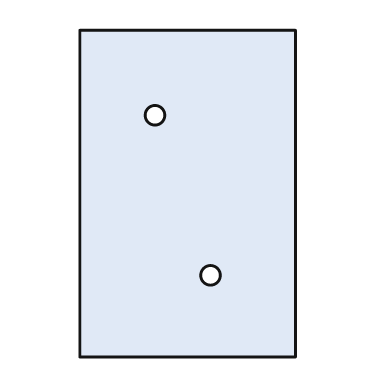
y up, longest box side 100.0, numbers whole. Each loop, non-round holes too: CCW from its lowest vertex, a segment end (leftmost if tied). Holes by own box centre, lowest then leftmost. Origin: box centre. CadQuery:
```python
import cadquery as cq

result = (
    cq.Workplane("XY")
    .moveTo(-33.0, -50.0)
    .lineTo(33.0, -50.0)
    .lineTo(33.0, 50.0)
    .lineTo(-33.0, 50.0)
    .close()
    .moveTo(7.0, -25.0)
    .circle(3.0)
    .moveTo(-10.0, 24.0)
    .circle(3.0)
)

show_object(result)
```